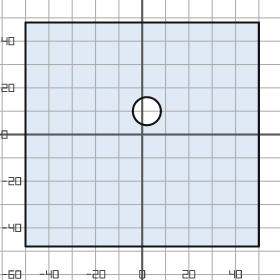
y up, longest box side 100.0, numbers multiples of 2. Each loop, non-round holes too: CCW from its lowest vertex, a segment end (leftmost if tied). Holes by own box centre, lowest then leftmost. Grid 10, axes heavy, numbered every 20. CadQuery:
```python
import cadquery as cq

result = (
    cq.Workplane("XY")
    .moveTo(-50.0, -48.0)
    .lineTo(50.0, -48.0)
    .lineTo(50.0, 48.0)
    .lineTo(-50.0, 48.0)
    .close()
    .moveTo(2.0, 10.0)
    .circle(6.0)
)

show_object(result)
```